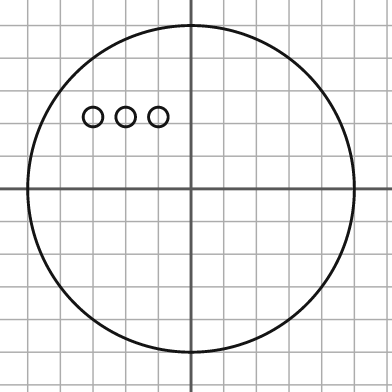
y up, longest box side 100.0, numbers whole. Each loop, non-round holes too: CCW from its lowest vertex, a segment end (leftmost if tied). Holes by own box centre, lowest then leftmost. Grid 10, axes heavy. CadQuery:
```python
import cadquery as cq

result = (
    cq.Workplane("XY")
    .moveTo(0.0, 0.0)
    .circle(50.0)
    .moveTo(-30.0, 22.0)
    .circle(3.0)
    .moveTo(-20.0, 22.0)
    .circle(3.0)
    .moveTo(-10.0, 22.0)
    .circle(3.0)
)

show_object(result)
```